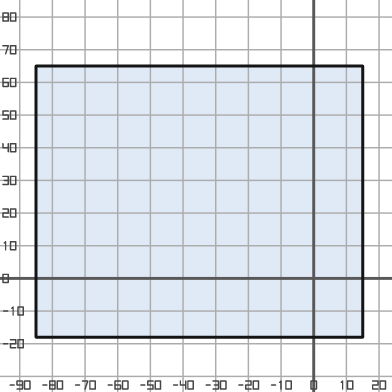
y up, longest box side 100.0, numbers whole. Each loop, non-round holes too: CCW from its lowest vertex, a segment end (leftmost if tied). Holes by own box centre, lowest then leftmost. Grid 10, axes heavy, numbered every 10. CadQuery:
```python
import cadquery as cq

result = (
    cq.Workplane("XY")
    .moveTo(-85.0, -18.0)
    .lineTo(15.0, -18.0)
    .lineTo(15.0, 65.0)
    .lineTo(-85.0, 65.0)
    .close()
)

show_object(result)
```